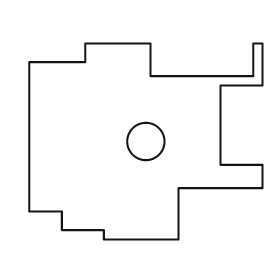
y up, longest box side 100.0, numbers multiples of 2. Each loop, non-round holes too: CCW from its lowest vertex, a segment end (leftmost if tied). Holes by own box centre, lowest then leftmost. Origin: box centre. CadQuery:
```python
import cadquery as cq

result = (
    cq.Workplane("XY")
    .moveTo(-18.0, -42.0)
    .lineTo(14.0, -42.0)
    .lineTo(14.0, -20.0)
    .lineTo(50.0, -20.0)
    .lineTo(50.0, -10.0)
    .lineTo(32.0, -10.0)
    .lineTo(32.0, 24.0)
    .lineTo(50.0, 24.0)
    .lineTo(50.0, 42.0)
    .lineTo(46.0, 42.0)
    .lineTo(46.0, 28.0)
    .lineTo(2.0, 28.0)
    .lineTo(2.0, 42.0)
    .lineTo(-26.0, 42.0)
    .lineTo(-26.0, 34.0)
    .lineTo(-50.0, 34.0)
    .lineTo(-50.0, -30.0)
    .lineTo(-36.0, -30.0)
    .lineTo(-36.0, -38.0)
    .lineTo(-18.0, -38.0)
    .close()
    .moveTo(0.0, 0.0)
    .circle(8.0)
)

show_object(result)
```